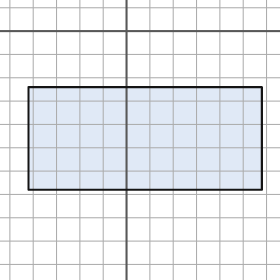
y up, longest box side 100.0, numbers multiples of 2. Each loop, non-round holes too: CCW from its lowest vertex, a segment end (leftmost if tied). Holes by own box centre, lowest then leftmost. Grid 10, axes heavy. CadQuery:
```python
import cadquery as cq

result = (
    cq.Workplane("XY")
    .moveTo(-42.0, -68.0)
    .lineTo(58.0, -68.0)
    .lineTo(58.0, -24.0)
    .lineTo(-42.0, -24.0)
    .close()
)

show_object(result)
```